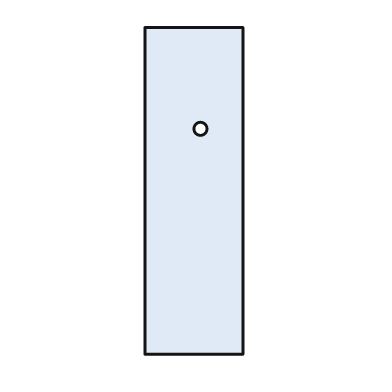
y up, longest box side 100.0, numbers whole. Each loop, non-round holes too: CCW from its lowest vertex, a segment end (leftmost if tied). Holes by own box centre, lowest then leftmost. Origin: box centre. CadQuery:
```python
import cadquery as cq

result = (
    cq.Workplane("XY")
    .moveTo(-15.0, -50.0)
    .lineTo(15.0, -50.0)
    .lineTo(15.0, 50.0)
    .lineTo(-15.0, 50.0)
    .close()
    .moveTo(2.0, 19.0)
    .circle(2.0)
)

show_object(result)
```